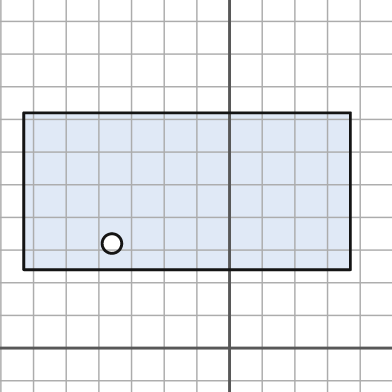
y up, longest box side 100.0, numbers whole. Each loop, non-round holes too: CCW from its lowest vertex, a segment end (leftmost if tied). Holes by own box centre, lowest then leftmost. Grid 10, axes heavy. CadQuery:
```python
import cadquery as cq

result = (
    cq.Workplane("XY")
    .moveTo(-63.0, 24.0)
    .lineTo(37.0, 24.0)
    .lineTo(37.0, 72.0)
    .lineTo(-63.0, 72.0)
    .close()
    .moveTo(-36.0, 32.0)
    .circle(3.0)
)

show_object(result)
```